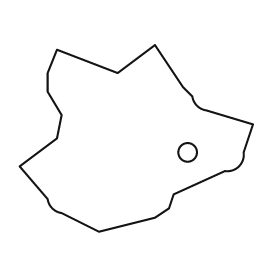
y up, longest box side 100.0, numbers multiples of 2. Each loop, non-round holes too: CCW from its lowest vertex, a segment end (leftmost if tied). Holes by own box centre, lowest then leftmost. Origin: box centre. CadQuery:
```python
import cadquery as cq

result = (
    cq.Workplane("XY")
    .moveTo(-16.0, -40.0)
    .lineTo(8.0, -34.0)
    .lineTo(14.0, -30.0)
    .lineTo(16.0, -24.0)
    .lineTo(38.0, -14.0)
    .threePointArc((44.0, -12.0), (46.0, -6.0))
    .lineTo(50.0, 6.0)
    .lineTo(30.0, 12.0)
    .threePointArc((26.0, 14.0), (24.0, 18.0))
    .lineTo(20.0, 22.0)
    .lineTo(8.0, 40.0)
    .lineTo(-8.0, 28.0)
    .lineTo(-34.0, 38.0)
    .lineTo(-38.0, 28.0)
    .lineTo(-38.0, 20.0)
    .lineTo(-32.0, 10.0)
    .lineTo(-34.0, 0.0)
    .lineTo(-50.0, -12.0)
    .lineTo(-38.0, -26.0)
    .threePointArc((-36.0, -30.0), (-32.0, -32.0))
    .close()
    .moveTo(22.0, -6.0)
    .circle(4.0)
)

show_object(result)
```